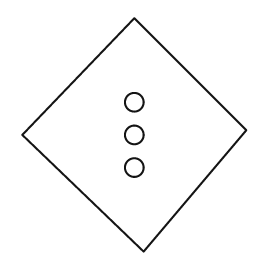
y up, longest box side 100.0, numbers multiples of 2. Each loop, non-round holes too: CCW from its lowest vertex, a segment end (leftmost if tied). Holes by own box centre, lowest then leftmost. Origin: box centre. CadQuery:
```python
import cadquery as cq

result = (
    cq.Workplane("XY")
    .moveTo(4.0, -50.0)
    .lineTo(48.0, 2.0)
    .lineTo(0.0, 50.0)
    .lineTo(-48.0, 0.0)
    .close()
    .moveTo(0.0, -14.0)
    .circle(4.0)
    .moveTo(0.0, 0.0)
    .circle(4.0)
    .moveTo(0.0, 14.0)
    .circle(4.0)
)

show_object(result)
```